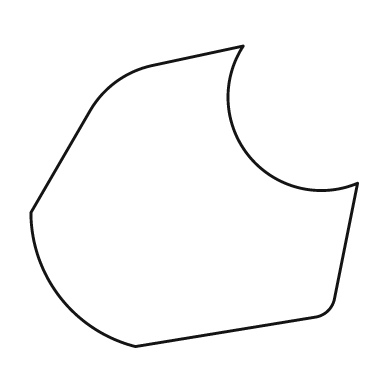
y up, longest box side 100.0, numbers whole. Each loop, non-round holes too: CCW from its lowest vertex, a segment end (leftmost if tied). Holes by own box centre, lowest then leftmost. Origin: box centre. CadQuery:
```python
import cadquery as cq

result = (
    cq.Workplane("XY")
    .moveTo(-18.0, -46.0)
    .lineTo(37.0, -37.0)
    .threePointArc((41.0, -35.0), (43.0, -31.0))
    .lineTo(50.0, 4.0)
    .threePointArc((17.0, 12.0), (15.0, 46.0))
    .lineTo(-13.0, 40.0)
    .threePointArc((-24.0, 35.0), (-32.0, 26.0))
    .lineTo(-50.0, -5.0)
    .threePointArc((-41.0, -31.0), (-18.0, -46.0))
    .close()
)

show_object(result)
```